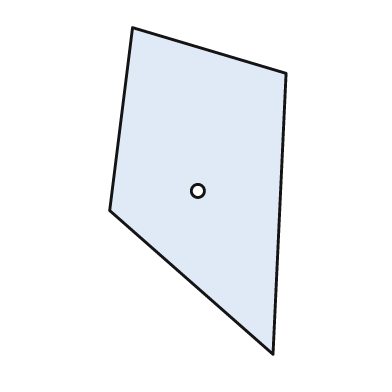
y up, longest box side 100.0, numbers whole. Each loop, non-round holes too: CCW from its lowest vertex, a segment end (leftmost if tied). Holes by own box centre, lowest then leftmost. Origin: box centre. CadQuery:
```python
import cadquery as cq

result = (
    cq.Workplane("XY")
    .moveTo(23.0, -50.0)
    .lineTo(27.0, 36.0)
    .lineTo(-20.0, 50.0)
    .lineTo(-27.0, -6.0)
    .close()
    .moveTo(0.0, 0.0)
    .circle(2.0)
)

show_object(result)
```